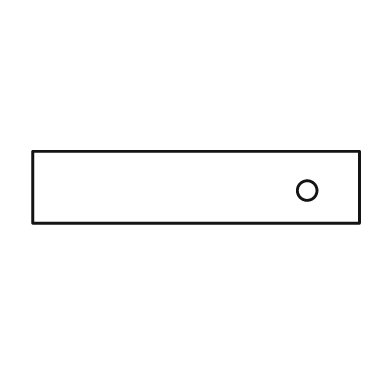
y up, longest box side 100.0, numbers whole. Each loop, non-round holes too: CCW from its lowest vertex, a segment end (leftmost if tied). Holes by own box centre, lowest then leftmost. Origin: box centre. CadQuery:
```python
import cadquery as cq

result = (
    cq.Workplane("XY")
    .moveTo(-50.0, -11.0)
    .lineTo(50.0, -11.0)
    .lineTo(50.0, 11.0)
    .lineTo(-50.0, 11.0)
    .close()
    .moveTo(34.0, -1.0)
    .circle(3.0)
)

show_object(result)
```